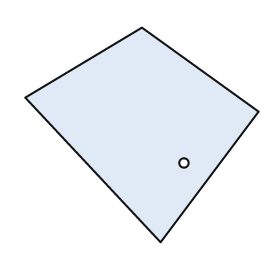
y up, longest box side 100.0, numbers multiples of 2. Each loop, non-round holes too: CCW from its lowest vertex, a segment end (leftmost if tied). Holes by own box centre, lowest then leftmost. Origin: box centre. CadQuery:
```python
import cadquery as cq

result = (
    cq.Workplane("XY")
    .moveTo(8.0, -46.0)
    .lineTo(50.0, 10.0)
    .lineTo(0.0, 46.0)
    .lineTo(-50.0, 16.0)
    .close()
    .moveTo(18.0, -12.0)
    .circle(2.0)
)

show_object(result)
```